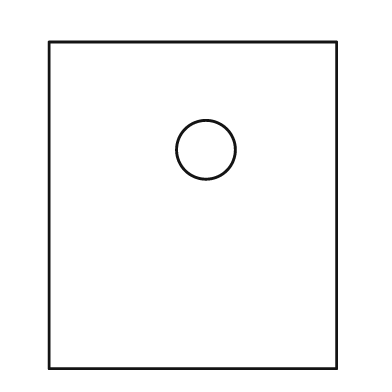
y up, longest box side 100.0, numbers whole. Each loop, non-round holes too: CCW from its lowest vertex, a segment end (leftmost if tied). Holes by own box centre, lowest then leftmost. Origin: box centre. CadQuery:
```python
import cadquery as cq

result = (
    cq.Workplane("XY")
    .moveTo(-44.0, -50.0)
    .lineTo(44.0, -50.0)
    .lineTo(44.0, 50.0)
    .lineTo(-44.0, 50.0)
    .close()
    .moveTo(4.0, 17.0)
    .circle(9.0)
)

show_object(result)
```